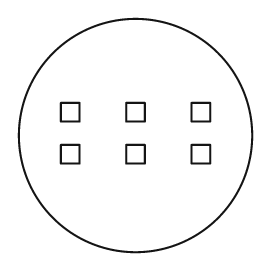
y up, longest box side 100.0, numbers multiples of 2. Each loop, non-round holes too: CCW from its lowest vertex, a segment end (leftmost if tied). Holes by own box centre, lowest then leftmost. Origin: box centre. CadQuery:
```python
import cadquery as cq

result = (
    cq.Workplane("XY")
    .moveTo(0.0, 0.0)
    .circle(50.0)
    .moveTo(-32.0, -12.0)
    .lineTo(-24.0, -12.0)
    .lineTo(-24.0, -4.0)
    .lineTo(-32.0, -4.0)
    .close()
    .moveTo(-4.0, -12.0)
    .lineTo(4.0, -12.0)
    .lineTo(4.0, -4.0)
    .lineTo(-4.0, -4.0)
    .close()
    .moveTo(24.0, -12.0)
    .lineTo(32.0, -12.0)
    .lineTo(32.0, -4.0)
    .lineTo(24.0, -4.0)
    .close()
    .moveTo(-32.0, 6.0)
    .lineTo(-24.0, 6.0)
    .lineTo(-24.0, 14.0)
    .lineTo(-32.0, 14.0)
    .close()
    .moveTo(-4.0, 6.0)
    .lineTo(4.0, 6.0)
    .lineTo(4.0, 14.0)
    .lineTo(-4.0, 14.0)
    .close()
    .moveTo(24.0, 6.0)
    .lineTo(32.0, 6.0)
    .lineTo(32.0, 14.0)
    .lineTo(24.0, 14.0)
    .close()
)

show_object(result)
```